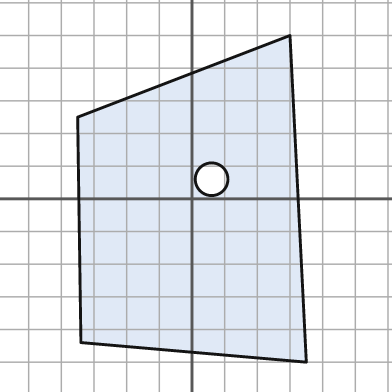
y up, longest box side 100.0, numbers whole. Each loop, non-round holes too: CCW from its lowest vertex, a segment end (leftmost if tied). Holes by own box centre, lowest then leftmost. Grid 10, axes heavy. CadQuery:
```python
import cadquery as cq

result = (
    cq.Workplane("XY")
    .moveTo(35.0, -50.0)
    .lineTo(30.0, 50.0)
    .lineTo(-35.0, 25.0)
    .lineTo(-34.0, -44.0)
    .close()
    .moveTo(6.0, 6.0)
    .circle(5.0)
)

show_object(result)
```